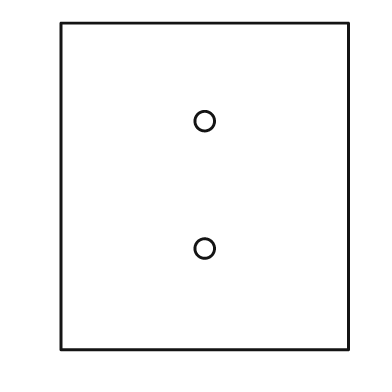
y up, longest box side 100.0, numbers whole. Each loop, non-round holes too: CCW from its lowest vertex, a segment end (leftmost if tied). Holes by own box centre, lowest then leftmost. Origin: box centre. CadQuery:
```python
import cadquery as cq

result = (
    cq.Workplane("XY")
    .moveTo(-44.0, -50.0)
    .lineTo(44.0, -50.0)
    .lineTo(44.0, 50.0)
    .lineTo(-44.0, 50.0)
    .close()
    .moveTo(0.0, -19.0)
    .circle(3.0)
    .moveTo(0.0, 20.0)
    .circle(3.0)
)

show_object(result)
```